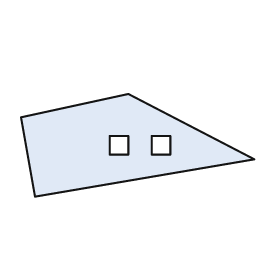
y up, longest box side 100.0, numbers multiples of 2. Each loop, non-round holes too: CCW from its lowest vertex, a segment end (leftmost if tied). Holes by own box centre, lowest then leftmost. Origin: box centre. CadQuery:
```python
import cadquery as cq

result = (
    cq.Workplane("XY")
    .moveTo(-44.0, -22.0)
    .lineTo(50.0, -6.0)
    .lineTo(-4.0, 22.0)
    .lineTo(-50.0, 12.0)
    .close()
    .moveTo(-12.0, -4.0)
    .lineTo(-4.0, -4.0)
    .lineTo(-4.0, 4.0)
    .lineTo(-12.0, 4.0)
    .close()
    .moveTo(6.0, -4.0)
    .lineTo(14.0, -4.0)
    .lineTo(14.0, 4.0)
    .lineTo(6.0, 4.0)
    .close()
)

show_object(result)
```